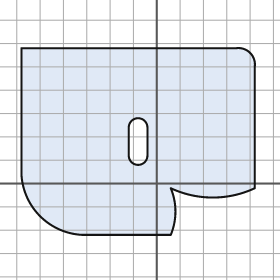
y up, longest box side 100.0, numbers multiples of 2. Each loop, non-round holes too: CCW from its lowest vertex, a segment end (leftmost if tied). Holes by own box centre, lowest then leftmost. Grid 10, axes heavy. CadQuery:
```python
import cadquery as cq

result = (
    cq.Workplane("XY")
    .moveTo(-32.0, -22.0)
    .lineTo(6.0, -22.0)
    .threePointArc((8.0, -12.0), (6.0, -2.0))
    .threePointArc((24.0, -6.0), (42.0, -2.0))
    .lineTo(42.0, 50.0)
    .threePointArc((40.0, 56.0), (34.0, 58.0))
    .lineTo(-58.0, 58.0)
    .lineTo(-58.0, 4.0)
    .threePointArc((-50.0, -14.0), (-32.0, -22.0))
    .close()
    .moveTo(-12.0, 12.0)
    .threePointArc((-8.0, 8.0), (-4.0, 12.0))
    .lineTo(-4.0, 24.0)
    .threePointArc((-8.0, 28.0), (-12.0, 24.0))
    .close()
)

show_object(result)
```